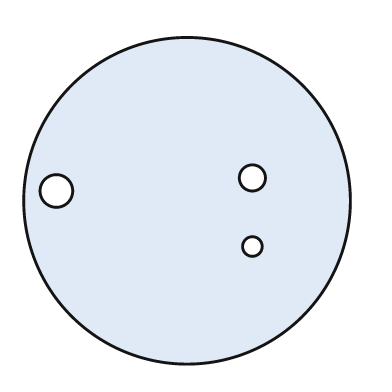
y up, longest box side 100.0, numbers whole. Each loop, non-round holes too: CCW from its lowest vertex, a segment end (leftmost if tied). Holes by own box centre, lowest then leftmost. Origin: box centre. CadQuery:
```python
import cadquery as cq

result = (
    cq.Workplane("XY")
    .moveTo(0.0, 0.0)
    .circle(50.0)
    .moveTo(20.0, -14.0)
    .circle(3.0)
    .moveTo(-40.0, 3.0)
    .circle(5.0)
    .moveTo(20.0, 7.0)
    .circle(4.0)
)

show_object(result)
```